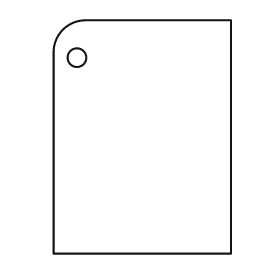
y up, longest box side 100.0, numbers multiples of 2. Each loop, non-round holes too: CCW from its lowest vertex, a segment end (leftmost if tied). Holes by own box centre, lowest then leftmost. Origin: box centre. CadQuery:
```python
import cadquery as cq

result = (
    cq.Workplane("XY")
    .moveTo(-38.0, -50.0)
    .lineTo(38.0, -50.0)
    .lineTo(38.0, 50.0)
    .lineTo(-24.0, 50.0)
    .threePointArc((-34.0, 46.0), (-38.0, 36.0))
    .close()
    .moveTo(-28.0, 34.0)
    .circle(4.0)
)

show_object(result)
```